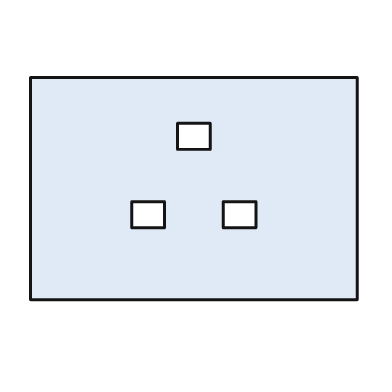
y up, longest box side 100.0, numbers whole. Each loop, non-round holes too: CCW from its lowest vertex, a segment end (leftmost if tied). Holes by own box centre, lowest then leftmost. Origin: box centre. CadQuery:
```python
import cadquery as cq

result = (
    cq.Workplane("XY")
    .moveTo(-50.0, -34.0)
    .lineTo(50.0, -34.0)
    .lineTo(50.0, 34.0)
    .lineTo(-50.0, 34.0)
    .close()
    .moveTo(-19.0, -12.0)
    .lineTo(-9.0, -12.0)
    .lineTo(-9.0, -4.0)
    .lineTo(-19.0, -4.0)
    .close()
    .moveTo(9.0, -12.0)
    .lineTo(19.0, -12.0)
    .lineTo(19.0, -4.0)
    .lineTo(9.0, -4.0)
    .close()
    .moveTo(-5.0, 12.0)
    .lineTo(5.0, 12.0)
    .lineTo(5.0, 20.0)
    .lineTo(-5.0, 20.0)
    .close()
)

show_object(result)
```